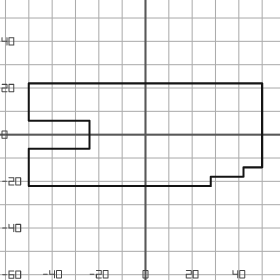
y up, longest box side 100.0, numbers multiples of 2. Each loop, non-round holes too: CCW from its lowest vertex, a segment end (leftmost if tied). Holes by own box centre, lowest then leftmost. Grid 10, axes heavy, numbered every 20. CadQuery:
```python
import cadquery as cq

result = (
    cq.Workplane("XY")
    .moveTo(-50.0, -22.0)
    .lineTo(28.0, -22.0)
    .lineTo(28.0, -18.0)
    .lineTo(42.0, -18.0)
    .lineTo(42.0, -14.0)
    .lineTo(50.0, -14.0)
    .lineTo(50.0, 22.0)
    .lineTo(-50.0, 22.0)
    .lineTo(-50.0, 6.0)
    .lineTo(-24.0, 6.0)
    .lineTo(-24.0, -6.0)
    .lineTo(-50.0, -6.0)
    .close()
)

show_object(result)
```